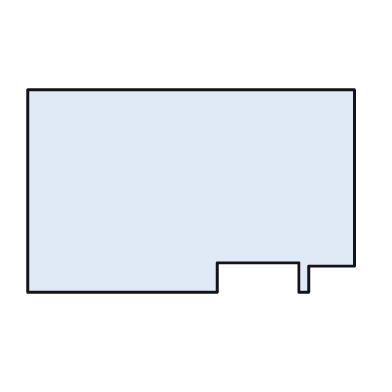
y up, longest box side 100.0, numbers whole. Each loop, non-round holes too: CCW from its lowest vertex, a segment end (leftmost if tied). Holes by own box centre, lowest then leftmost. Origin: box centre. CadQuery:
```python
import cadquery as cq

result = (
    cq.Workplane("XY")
    .moveTo(-50.0, -31.0)
    .lineTo(8.0, -31.0)
    .lineTo(8.0, -22.0)
    .lineTo(33.0, -22.0)
    .lineTo(33.0, -31.0)
    .lineTo(36.0, -31.0)
    .lineTo(36.0, -23.0)
    .lineTo(50.0, -23.0)
    .lineTo(50.0, 31.0)
    .lineTo(-50.0, 31.0)
    .close()
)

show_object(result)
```